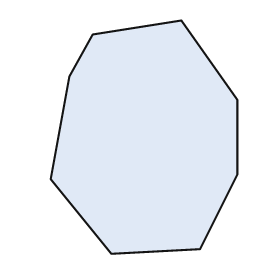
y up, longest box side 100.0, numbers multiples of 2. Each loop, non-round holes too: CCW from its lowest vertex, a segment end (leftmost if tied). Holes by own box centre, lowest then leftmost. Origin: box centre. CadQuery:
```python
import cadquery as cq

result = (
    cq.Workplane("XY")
    .moveTo(-14.0, -50.0)
    .lineTo(24.0, -48.0)
    .lineTo(40.0, -16.0)
    .lineTo(40.0, 16.0)
    .lineTo(16.0, 50.0)
    .lineTo(-22.0, 44.0)
    .lineTo(-32.0, 26.0)
    .lineTo(-40.0, -18.0)
    .close()
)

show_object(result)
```